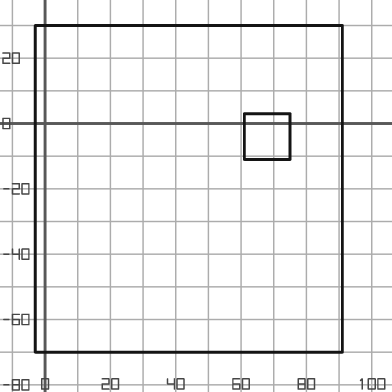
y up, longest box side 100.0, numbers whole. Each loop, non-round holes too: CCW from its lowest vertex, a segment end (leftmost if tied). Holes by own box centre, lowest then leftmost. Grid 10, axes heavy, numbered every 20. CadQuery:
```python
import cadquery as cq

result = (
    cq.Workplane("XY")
    .moveTo(-3.0, -70.0)
    .lineTo(91.0, -70.0)
    .lineTo(91.0, 30.0)
    .lineTo(-3.0, 30.0)
    .close()
    .moveTo(61.0, -11.0)
    .lineTo(75.0, -11.0)
    .lineTo(75.0, 3.0)
    .lineTo(61.0, 3.0)
    .close()
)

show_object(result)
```